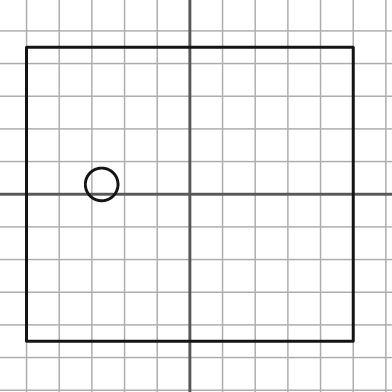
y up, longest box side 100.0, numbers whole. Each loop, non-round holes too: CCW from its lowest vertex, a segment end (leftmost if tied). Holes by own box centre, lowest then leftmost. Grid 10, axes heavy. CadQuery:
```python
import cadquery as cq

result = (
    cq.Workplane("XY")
    .moveTo(-50.0, -45.0)
    .lineTo(50.0, -45.0)
    .lineTo(50.0, 45.0)
    .lineTo(-50.0, 45.0)
    .close()
    .moveTo(-27.0, 3.0)
    .circle(5.0)
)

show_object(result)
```